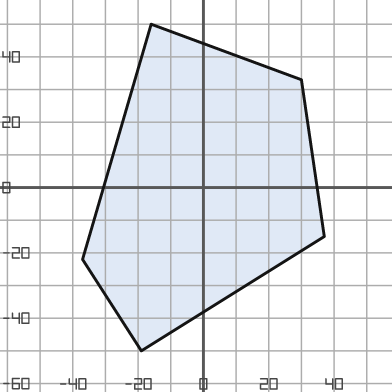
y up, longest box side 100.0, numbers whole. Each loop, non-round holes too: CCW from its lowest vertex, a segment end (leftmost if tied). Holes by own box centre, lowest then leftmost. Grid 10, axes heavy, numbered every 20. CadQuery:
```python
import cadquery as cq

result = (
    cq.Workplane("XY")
    .moveTo(-19.0, -50.0)
    .lineTo(37.0, -15.0)
    .lineTo(30.0, 33.0)
    .lineTo(-16.0, 50.0)
    .lineTo(-37.0, -22.0)
    .close()
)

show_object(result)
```